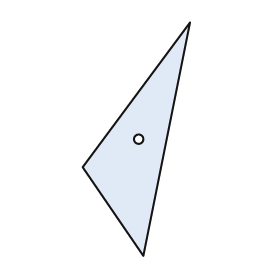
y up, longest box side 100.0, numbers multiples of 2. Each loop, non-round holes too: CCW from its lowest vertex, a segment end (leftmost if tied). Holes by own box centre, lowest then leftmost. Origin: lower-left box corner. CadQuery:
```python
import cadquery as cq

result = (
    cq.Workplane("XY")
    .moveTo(26.0, 0.0)
    .lineTo(46.0, 100.0)
    .lineTo(0.0, 38.0)
    .close()
    .moveTo(24.0, 50.0)
    .circle(2.0)
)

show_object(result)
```